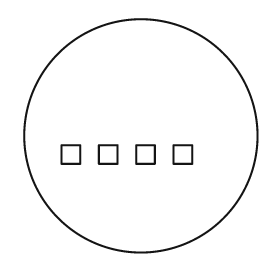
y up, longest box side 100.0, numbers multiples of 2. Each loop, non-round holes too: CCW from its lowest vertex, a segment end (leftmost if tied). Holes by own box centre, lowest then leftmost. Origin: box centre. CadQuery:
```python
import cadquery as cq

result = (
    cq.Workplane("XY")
    .moveTo(0.0, 0.0)
    .circle(50.0)
    .moveTo(-34.0, -12.0)
    .lineTo(-26.0, -12.0)
    .lineTo(-26.0, -4.0)
    .lineTo(-34.0, -4.0)
    .close()
    .moveTo(-18.0, -12.0)
    .lineTo(-10.0, -12.0)
    .lineTo(-10.0, -4.0)
    .lineTo(-18.0, -4.0)
    .close()
    .moveTo(-2.0, -12.0)
    .lineTo(6.0, -12.0)
    .lineTo(6.0, -4.0)
    .lineTo(-2.0, -4.0)
    .close()
    .moveTo(14.0, -12.0)
    .lineTo(22.0, -12.0)
    .lineTo(22.0, -4.0)
    .lineTo(14.0, -4.0)
    .close()
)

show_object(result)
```